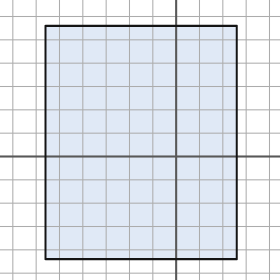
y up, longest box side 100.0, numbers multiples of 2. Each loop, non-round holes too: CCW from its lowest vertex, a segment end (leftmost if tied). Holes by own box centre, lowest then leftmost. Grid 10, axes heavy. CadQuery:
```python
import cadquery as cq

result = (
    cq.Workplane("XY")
    .moveTo(-56.0, -44.0)
    .lineTo(26.0, -44.0)
    .lineTo(26.0, 56.0)
    .lineTo(-56.0, 56.0)
    .close()
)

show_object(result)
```